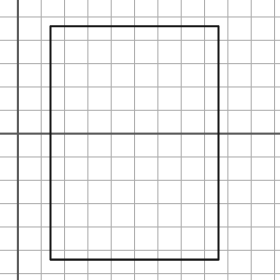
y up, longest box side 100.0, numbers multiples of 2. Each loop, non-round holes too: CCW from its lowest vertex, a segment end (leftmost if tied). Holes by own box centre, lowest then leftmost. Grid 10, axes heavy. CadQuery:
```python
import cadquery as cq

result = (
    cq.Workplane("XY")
    .moveTo(14.0, -54.0)
    .lineTo(86.0, -54.0)
    .lineTo(86.0, 46.0)
    .lineTo(14.0, 46.0)
    .close()
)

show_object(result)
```